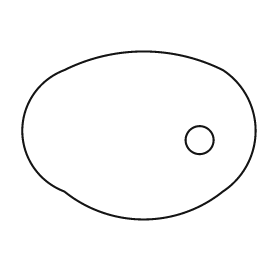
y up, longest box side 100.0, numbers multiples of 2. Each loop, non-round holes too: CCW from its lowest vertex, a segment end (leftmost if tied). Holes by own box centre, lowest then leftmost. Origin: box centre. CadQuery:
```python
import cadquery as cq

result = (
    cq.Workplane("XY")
    .moveTo(-32.0, -24.0)
    .threePointArc((2.0, -36.0), (36.0, -24.0))
    .threePointArc((50.0, 2.0), (36.0, 28.0))
    .threePointArc((2.0, 36.0), (-32.0, 28.0))
    .threePointArc((-50.0, 2.0), (-32.0, -24.0))
    .close()
    .moveTo(26.0, -2.0)
    .circle(6.0)
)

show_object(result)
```